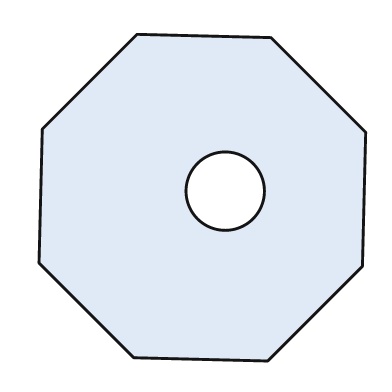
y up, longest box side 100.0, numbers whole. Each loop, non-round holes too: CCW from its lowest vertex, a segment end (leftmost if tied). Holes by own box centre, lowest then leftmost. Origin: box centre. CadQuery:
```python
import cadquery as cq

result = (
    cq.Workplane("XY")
    .moveTo(20.0, -50.0)
    .lineTo(49.0, -21.0)
    .lineTo(50.0, 20.0)
    .lineTo(21.0, 49.0)
    .lineTo(-20.0, 50.0)
    .lineTo(-49.0, 21.0)
    .lineTo(-50.0, -20.0)
    .lineTo(-21.0, -49.0)
    .close()
    .moveTo(7.0, 2.0)
    .circle(12.0)
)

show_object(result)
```